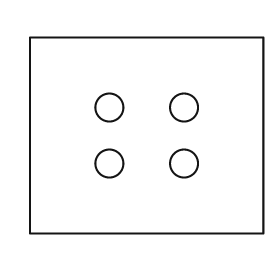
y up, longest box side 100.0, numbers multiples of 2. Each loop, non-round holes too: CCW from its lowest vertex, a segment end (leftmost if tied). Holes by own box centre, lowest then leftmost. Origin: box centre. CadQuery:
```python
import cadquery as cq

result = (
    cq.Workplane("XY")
    .moveTo(-50.0, -42.0)
    .lineTo(50.0, -42.0)
    .lineTo(50.0, 42.0)
    .lineTo(-50.0, 42.0)
    .close()
    .moveTo(-16.0, -12.0)
    .circle(6.0)
    .moveTo(16.0, -12.0)
    .circle(6.0)
    .moveTo(-16.0, 12.0)
    .circle(6.0)
    .moveTo(16.0, 12.0)
    .circle(6.0)
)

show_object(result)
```